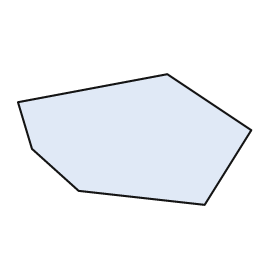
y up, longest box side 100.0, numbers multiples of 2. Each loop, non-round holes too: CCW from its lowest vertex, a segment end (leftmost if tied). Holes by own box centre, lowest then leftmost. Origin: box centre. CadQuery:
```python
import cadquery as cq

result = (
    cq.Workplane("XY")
    .moveTo(30.0, -28.0)
    .lineTo(50.0, 4.0)
    .lineTo(14.0, 28.0)
    .lineTo(-50.0, 16.0)
    .lineTo(-44.0, -4.0)
    .lineTo(-24.0, -22.0)
    .close()
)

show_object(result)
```